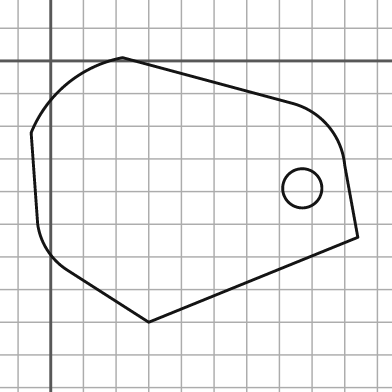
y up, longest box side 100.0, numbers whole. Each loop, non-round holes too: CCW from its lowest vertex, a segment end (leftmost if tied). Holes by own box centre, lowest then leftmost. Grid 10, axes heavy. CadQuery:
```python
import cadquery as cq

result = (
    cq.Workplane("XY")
    .moveTo(30.0, -80.0)
    .lineTo(94.0, -54.0)
    .lineTo(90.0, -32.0)
    .threePointArc((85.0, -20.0), (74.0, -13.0))
    .lineTo(22.0, 1.0)
    .threePointArc((5.0, -7.0), (-6.0, -22.0))
    .lineTo(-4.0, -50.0)
    .threePointArc((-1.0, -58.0), (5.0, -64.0))
    .close()
    .moveTo(77.0, -39.0)
    .circle(6.0)
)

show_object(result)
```